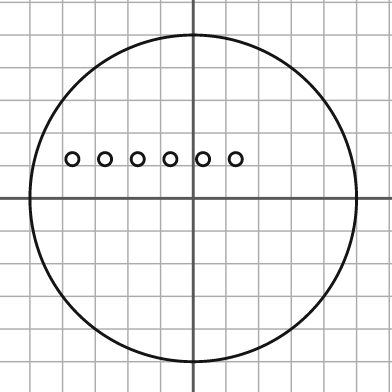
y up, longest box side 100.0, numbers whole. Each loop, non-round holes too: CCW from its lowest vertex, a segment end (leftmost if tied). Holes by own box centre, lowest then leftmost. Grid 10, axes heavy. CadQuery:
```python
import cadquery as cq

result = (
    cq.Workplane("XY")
    .moveTo(0.0, 0.0)
    .circle(50.0)
    .moveTo(-37.0, 12.0)
    .circle(2.0)
    .moveTo(-27.0, 12.0)
    .circle(2.0)
    .moveTo(-17.0, 12.0)
    .circle(2.0)
    .moveTo(-7.0, 12.0)
    .circle(2.0)
    .moveTo(3.0, 12.0)
    .circle(2.0)
    .moveTo(13.0, 12.0)
    .circle(2.0)
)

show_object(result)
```